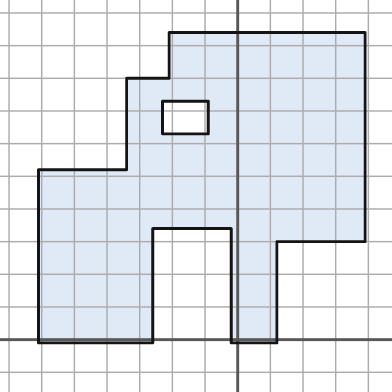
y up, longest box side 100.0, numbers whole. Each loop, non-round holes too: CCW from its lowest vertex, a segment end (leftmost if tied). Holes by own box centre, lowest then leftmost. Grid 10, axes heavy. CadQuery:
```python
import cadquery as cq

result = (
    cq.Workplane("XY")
    .moveTo(-61.0, -1.0)
    .lineTo(-26.0, -1.0)
    .lineTo(-26.0, 34.0)
    .lineTo(-2.0, 34.0)
    .lineTo(-2.0, -1.0)
    .lineTo(12.0, -1.0)
    .lineTo(12.0, 30.0)
    .lineTo(39.0, 30.0)
    .lineTo(39.0, 94.0)
    .lineTo(-21.0, 94.0)
    .lineTo(-21.0, 80.0)
    .lineTo(-34.0, 80.0)
    .lineTo(-34.0, 52.0)
    .lineTo(-61.0, 52.0)
    .close()
    .moveTo(-23.0, 63.0)
    .lineTo(-9.0, 63.0)
    .lineTo(-9.0, 73.0)
    .lineTo(-23.0, 73.0)
    .close()
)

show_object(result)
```